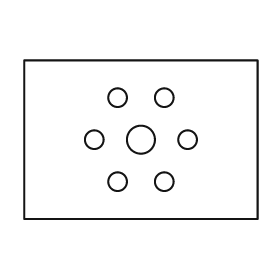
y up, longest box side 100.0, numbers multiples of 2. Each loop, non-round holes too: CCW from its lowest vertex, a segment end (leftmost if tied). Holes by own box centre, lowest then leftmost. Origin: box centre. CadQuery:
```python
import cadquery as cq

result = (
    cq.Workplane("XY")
    .moveTo(-50.0, -34.0)
    .lineTo(50.0, -34.0)
    .lineTo(50.0, 34.0)
    .lineTo(-50.0, 34.0)
    .close()
    .moveTo(-10.0, -18.0)
    .circle(4.0)
    .moveTo(10.0, -18.0)
    .circle(4.0)
    .moveTo(-20.0, 0.0)
    .circle(4.0)
    .moveTo(0.0, 0.0)
    .circle(6.0)
    .moveTo(20.0, 0.0)
    .circle(4.0)
    .moveTo(-10.0, 18.0)
    .circle(4.0)
    .moveTo(10.0, 18.0)
    .circle(4.0)
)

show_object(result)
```